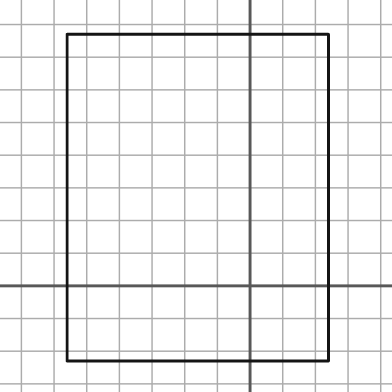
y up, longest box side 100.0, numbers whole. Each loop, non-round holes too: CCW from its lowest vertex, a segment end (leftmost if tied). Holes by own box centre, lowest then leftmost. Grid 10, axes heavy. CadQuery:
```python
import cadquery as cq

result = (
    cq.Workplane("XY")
    .moveTo(-56.0, -23.0)
    .lineTo(24.0, -23.0)
    .lineTo(24.0, 77.0)
    .lineTo(-56.0, 77.0)
    .close()
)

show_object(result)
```